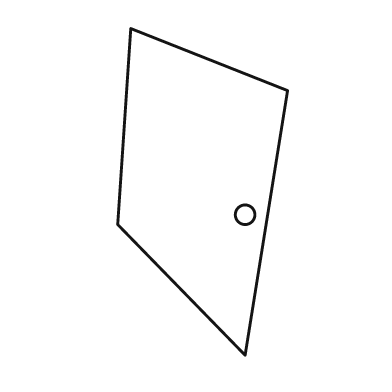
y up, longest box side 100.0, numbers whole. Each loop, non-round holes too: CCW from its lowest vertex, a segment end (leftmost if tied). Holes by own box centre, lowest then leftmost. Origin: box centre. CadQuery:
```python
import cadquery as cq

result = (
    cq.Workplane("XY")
    .moveTo(13.0, -50.0)
    .lineTo(26.0, 31.0)
    .lineTo(-22.0, 50.0)
    .lineTo(-26.0, -10.0)
    .close()
    .moveTo(13.0, -7.0)
    .circle(3.0)
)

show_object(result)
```